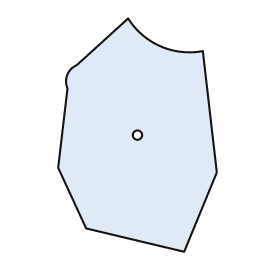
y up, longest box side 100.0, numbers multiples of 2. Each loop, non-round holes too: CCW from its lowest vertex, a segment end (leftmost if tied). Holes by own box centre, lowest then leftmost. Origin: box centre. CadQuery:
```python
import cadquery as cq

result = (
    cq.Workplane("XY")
    .moveTo(20.0, -50.0)
    .lineTo(34.0, -16.0)
    .lineTo(28.0, 36.0)
    .threePointArc((10.0, 38.0), (-4.0, 50.0))
    .lineTo(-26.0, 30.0)
    .threePointArc((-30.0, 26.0), (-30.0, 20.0))
    .lineTo(-34.0, -14.0)
    .lineTo(-22.0, -40.0)
    .close()
    .moveTo(0.0, 0.0)
    .circle(2.0)
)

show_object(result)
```